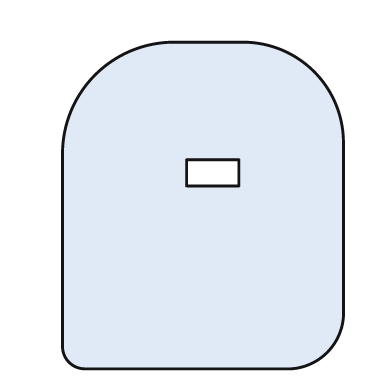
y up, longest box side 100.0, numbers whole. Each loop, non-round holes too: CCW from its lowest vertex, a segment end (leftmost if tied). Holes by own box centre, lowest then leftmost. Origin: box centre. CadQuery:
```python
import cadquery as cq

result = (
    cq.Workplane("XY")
    .moveTo(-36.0, -50.0)
    .lineTo(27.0, -50.0)
    .threePointArc((38.0, -45.0), (43.0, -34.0))
    .lineTo(43.0, 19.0)
    .threePointArc((34.0, 41.0), (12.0, 50.0))
    .lineTo(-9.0, 50.0)
    .threePointArc((-33.0, 40.0), (-43.0, 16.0))
    .lineTo(-43.0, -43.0)
    .threePointArc((-41.0, -48.0), (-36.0, -50.0))
    .close()
    .moveTo(-5.0, 6.0)
    .lineTo(11.0, 6.0)
    .lineTo(11.0, 14.0)
    .lineTo(-5.0, 14.0)
    .close()
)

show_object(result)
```